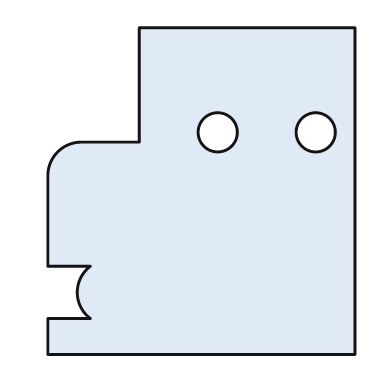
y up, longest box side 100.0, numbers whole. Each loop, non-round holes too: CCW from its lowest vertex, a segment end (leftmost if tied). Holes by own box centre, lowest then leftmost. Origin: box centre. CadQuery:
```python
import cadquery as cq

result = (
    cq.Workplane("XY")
    .moveTo(-47.0, -50.0)
    .lineTo(47.0, -50.0)
    .lineTo(47.0, 50.0)
    .lineTo(-19.0, 50.0)
    .lineTo(-19.0, 15.0)
    .lineTo(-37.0, 15.0)
    .threePointArc((-44.0, 12.0), (-47.0, 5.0))
    .lineTo(-47.0, -23.0)
    .lineTo(-34.0, -23.0)
    .threePointArc((-38.0, -31.0), (-34.0, -39.0))
    .lineTo(-47.0, -39.0)
    .close()
    .moveTo(5.0, 18.0)
    .circle(6.0)
    .moveTo(35.0, 18.0)
    .circle(6.0)
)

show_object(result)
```